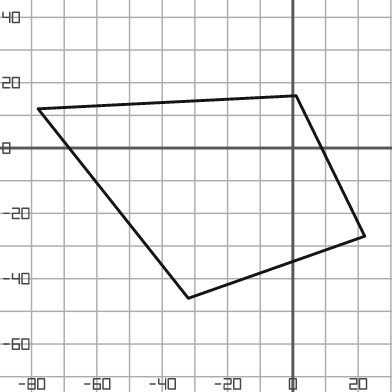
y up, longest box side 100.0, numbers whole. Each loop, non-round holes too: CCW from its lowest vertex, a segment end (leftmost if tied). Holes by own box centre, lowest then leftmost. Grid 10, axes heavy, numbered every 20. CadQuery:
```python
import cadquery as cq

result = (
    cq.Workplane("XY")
    .moveTo(-32.0, -46.0)
    .lineTo(22.0, -27.0)
    .lineTo(1.0, 16.0)
    .lineTo(-78.0, 12.0)
    .close()
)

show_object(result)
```